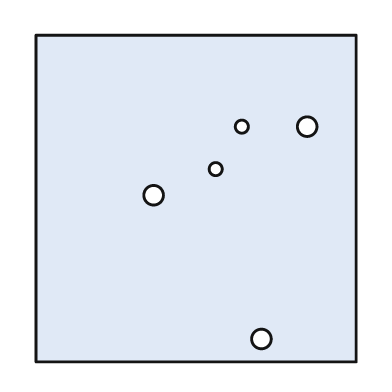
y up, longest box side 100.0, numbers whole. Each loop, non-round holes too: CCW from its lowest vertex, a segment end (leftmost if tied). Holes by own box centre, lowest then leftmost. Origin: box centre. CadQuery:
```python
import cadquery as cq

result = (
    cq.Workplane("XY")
    .moveTo(-49.0, -50.0)
    .lineTo(49.0, -50.0)
    .lineTo(49.0, 50.0)
    .lineTo(-49.0, 50.0)
    .close()
    .moveTo(20.0, -43.0)
    .circle(3.0)
    .moveTo(-13.0, 1.0)
    .circle(3.0)
    .moveTo(6.0, 9.0)
    .circle(2.0)
    .moveTo(14.0, 22.0)
    .circle(2.0)
    .moveTo(34.0, 22.0)
    .circle(3.0)
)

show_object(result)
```